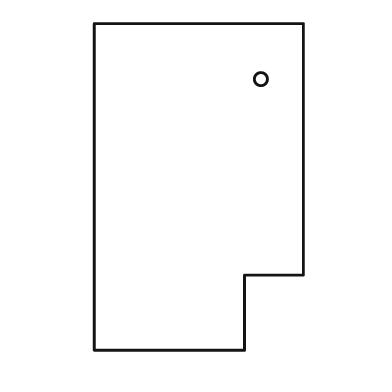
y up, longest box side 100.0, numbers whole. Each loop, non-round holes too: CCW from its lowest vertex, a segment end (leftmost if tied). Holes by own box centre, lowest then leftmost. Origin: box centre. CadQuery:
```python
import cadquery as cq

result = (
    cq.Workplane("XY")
    .moveTo(-32.0, -50.0)
    .lineTo(14.0, -50.0)
    .lineTo(14.0, -27.0)
    .lineTo(32.0, -27.0)
    .lineTo(32.0, 50.0)
    .lineTo(-32.0, 50.0)
    .close()
    .moveTo(19.0, 33.0)
    .circle(2.0)
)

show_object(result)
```